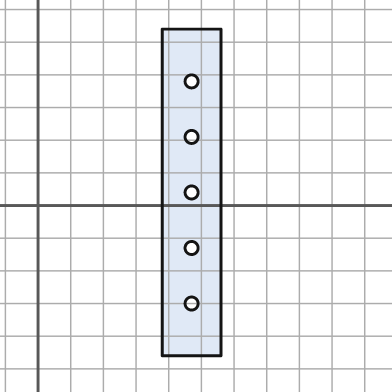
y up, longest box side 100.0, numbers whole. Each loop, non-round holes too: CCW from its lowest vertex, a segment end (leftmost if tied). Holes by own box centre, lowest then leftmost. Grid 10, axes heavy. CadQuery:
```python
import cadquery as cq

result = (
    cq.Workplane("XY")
    .moveTo(38.0, -46.0)
    .lineTo(56.0, -46.0)
    .lineTo(56.0, 54.0)
    .lineTo(38.0, 54.0)
    .close()
    .moveTo(47.0, -30.0)
    .circle(2.0)
    .moveTo(47.0, -13.0)
    .circle(2.0)
    .moveTo(47.0, 4.0)
    .circle(2.0)
    .moveTo(47.0, 21.0)
    .circle(2.0)
    .moveTo(47.0, 38.0)
    .circle(2.0)
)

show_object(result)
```